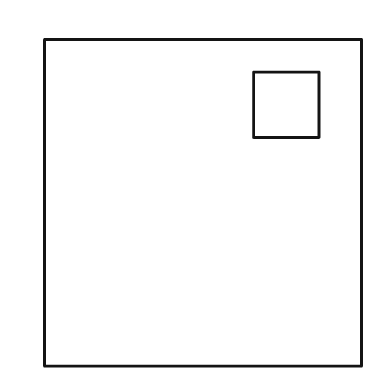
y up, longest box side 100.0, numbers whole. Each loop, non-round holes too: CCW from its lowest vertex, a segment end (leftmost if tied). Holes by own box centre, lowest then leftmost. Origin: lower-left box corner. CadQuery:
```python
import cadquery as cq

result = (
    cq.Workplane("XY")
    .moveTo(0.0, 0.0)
    .lineTo(97.0, 0.0)
    .lineTo(97.0, 100.0)
    .lineTo(0.0, 100.0)
    .close()
    .moveTo(64.0, 70.0)
    .lineTo(84.0, 70.0)
    .lineTo(84.0, 90.0)
    .lineTo(64.0, 90.0)
    .close()
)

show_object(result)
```